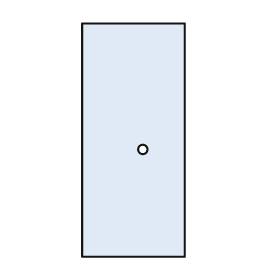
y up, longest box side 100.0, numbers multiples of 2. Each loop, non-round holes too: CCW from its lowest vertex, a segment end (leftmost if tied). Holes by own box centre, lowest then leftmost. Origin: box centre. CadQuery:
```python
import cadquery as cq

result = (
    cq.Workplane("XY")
    .moveTo(-22.0, -50.0)
    .lineTo(22.0, -50.0)
    .lineTo(22.0, 50.0)
    .lineTo(-22.0, 50.0)
    .close()
    .moveTo(4.0, -4.0)
    .circle(2.0)
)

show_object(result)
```